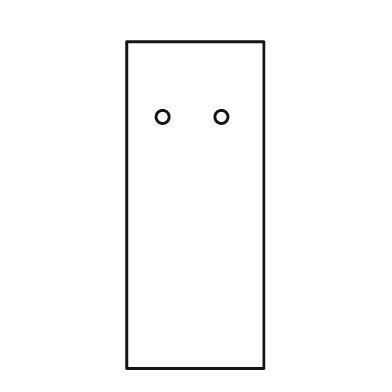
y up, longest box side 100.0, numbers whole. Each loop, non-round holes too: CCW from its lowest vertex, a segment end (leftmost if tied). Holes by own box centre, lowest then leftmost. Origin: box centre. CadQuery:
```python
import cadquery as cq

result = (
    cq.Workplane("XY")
    .moveTo(-21.0, -50.0)
    .lineTo(21.0, -50.0)
    .lineTo(21.0, 50.0)
    .lineTo(-21.0, 50.0)
    .close()
    .moveTo(-10.0, 27.0)
    .circle(2.0)
    .moveTo(8.0, 27.0)
    .circle(2.0)
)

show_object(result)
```